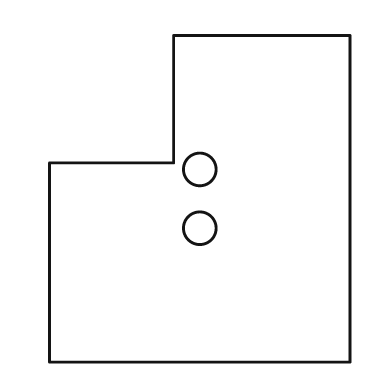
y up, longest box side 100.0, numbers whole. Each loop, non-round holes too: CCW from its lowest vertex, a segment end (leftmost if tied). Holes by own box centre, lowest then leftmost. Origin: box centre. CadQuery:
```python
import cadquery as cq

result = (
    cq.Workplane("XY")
    .moveTo(-46.0, -50.0)
    .lineTo(46.0, -50.0)
    .lineTo(46.0, 50.0)
    .lineTo(-8.0, 50.0)
    .lineTo(-8.0, 11.0)
    .lineTo(-46.0, 11.0)
    .close()
    .moveTo(0.0, -9.0)
    .circle(5.0)
    .moveTo(0.0, 9.0)
    .circle(5.0)
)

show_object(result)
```